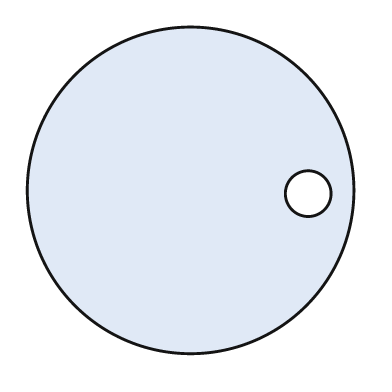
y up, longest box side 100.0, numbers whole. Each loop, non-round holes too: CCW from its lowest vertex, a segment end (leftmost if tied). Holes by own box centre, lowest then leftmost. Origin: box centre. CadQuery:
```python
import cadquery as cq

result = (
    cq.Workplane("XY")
    .moveTo(0.0, 0.0)
    .circle(50.0)
    .moveTo(36.0, -1.0)
    .circle(7.0)
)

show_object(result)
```